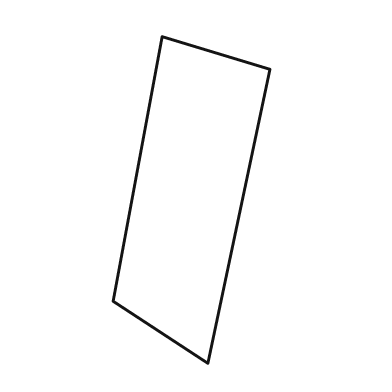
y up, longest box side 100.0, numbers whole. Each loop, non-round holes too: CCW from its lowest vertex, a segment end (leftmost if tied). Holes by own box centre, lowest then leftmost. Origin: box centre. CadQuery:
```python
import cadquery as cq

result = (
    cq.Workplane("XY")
    .moveTo(5.0, -50.0)
    .lineTo(24.0, 40.0)
    .lineTo(-9.0, 50.0)
    .lineTo(-24.0, -31.0)
    .close()
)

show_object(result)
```